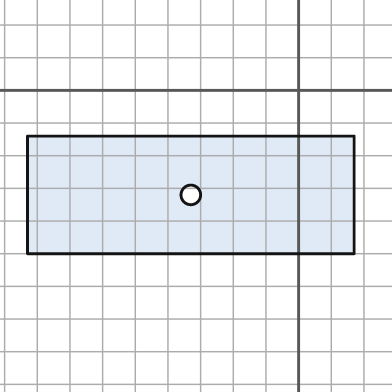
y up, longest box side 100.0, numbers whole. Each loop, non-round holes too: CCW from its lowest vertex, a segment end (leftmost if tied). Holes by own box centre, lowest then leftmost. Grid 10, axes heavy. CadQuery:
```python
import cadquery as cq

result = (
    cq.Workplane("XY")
    .moveTo(-83.0, -50.0)
    .lineTo(17.0, -50.0)
    .lineTo(17.0, -14.0)
    .lineTo(-83.0, -14.0)
    .close()
    .moveTo(-33.0, -32.0)
    .circle(3.0)
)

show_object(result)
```